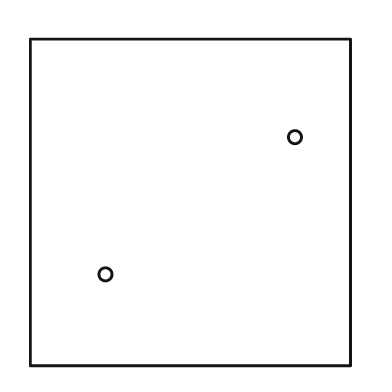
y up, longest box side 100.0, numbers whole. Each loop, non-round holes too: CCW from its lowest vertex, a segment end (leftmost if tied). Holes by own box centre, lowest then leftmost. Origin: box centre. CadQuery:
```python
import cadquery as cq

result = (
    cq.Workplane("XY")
    .moveTo(-49.0, -50.0)
    .lineTo(49.0, -50.0)
    .lineTo(49.0, 50.0)
    .lineTo(-49.0, 50.0)
    .close()
    .moveTo(-26.0, -22.0)
    .circle(2.0)
    .moveTo(32.0, 20.0)
    .circle(2.0)
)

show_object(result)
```